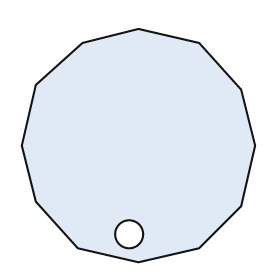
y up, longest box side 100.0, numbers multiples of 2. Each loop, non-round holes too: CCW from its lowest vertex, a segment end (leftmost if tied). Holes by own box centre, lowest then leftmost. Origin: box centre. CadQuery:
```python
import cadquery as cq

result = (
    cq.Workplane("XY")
    .moveTo(0.0, -50.0)
    .lineTo(26.0, -44.0)
    .lineTo(44.0, -26.0)
    .lineTo(50.0, 0.0)
    .lineTo(44.0, 24.0)
    .lineTo(26.0, 44.0)
    .lineTo(0.0, 50.0)
    .lineTo(-24.0, 44.0)
    .lineTo(-44.0, 26.0)
    .lineTo(-50.0, 0.0)
    .lineTo(-44.0, -24.0)
    .lineTo(-26.0, -44.0)
    .close()
    .moveTo(-4.0, -38.0)
    .circle(6.0)
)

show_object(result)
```